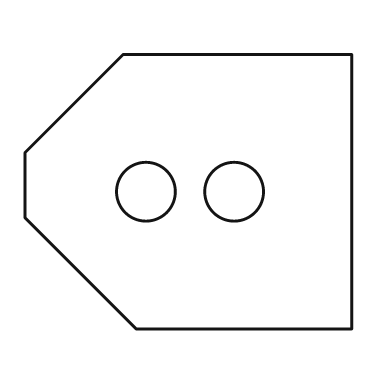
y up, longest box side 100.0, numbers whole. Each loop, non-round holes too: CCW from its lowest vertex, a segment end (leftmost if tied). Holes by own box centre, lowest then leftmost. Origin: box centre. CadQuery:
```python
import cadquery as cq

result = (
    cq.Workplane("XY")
    .moveTo(-16.0, -42.0)
    .lineTo(50.0, -42.0)
    .lineTo(50.0, 42.0)
    .lineTo(-20.0, 42.0)
    .lineTo(-50.0, 12.0)
    .lineTo(-50.0, -8.0)
    .close()
    .moveTo(-13.0, 0.0)
    .circle(9.0)
    .moveTo(14.0, 0.0)
    .circle(9.0)
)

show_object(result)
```